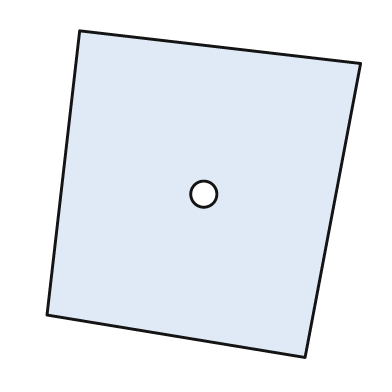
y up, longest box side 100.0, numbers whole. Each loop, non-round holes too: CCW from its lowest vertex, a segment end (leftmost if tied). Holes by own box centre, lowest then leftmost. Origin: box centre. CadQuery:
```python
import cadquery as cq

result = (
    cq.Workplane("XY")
    .moveTo(31.0, -50.0)
    .lineTo(48.0, 40.0)
    .lineTo(-38.0, 50.0)
    .lineTo(-48.0, -37.0)
    .close()
    .moveTo(0.0, 0.0)
    .circle(4.0)
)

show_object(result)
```